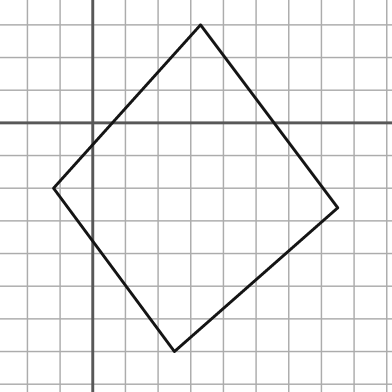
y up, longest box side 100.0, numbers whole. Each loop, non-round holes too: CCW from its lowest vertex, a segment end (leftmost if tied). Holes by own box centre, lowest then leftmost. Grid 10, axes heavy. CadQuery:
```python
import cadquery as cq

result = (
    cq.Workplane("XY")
    .moveTo(25.0, -70.0)
    .lineTo(75.0, -26.0)
    .lineTo(33.0, 30.0)
    .lineTo(-12.0, -20.0)
    .close()
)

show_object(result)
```